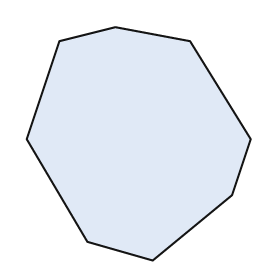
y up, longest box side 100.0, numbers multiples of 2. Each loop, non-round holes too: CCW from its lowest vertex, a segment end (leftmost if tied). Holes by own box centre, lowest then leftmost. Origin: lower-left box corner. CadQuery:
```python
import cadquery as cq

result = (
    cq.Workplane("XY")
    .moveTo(54.0, 0.0)
    .lineTo(88.0, 28.0)
    .lineTo(96.0, 52.0)
    .lineTo(70.0, 94.0)
    .lineTo(38.0, 100.0)
    .lineTo(14.0, 94.0)
    .lineTo(0.0, 52.0)
    .lineTo(26.0, 8.0)
    .close()
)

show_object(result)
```